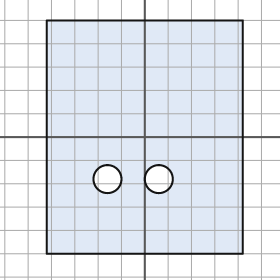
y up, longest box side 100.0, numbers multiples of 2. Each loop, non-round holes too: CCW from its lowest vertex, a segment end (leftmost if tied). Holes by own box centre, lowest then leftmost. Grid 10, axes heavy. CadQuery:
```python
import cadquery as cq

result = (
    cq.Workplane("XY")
    .moveTo(-42.0, -50.0)
    .lineTo(42.0, -50.0)
    .lineTo(42.0, 50.0)
    .lineTo(-42.0, 50.0)
    .close()
    .moveTo(-16.0, -18.0)
    .circle(6.0)
    .moveTo(6.0, -18.0)
    .circle(6.0)
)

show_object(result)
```